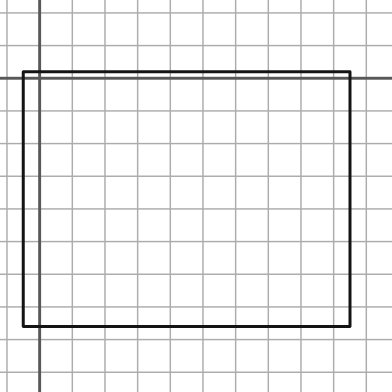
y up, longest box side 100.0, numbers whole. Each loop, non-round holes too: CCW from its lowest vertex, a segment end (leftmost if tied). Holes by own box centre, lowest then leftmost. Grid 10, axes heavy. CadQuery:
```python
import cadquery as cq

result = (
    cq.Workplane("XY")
    .moveTo(-5.0, -76.0)
    .lineTo(95.0, -76.0)
    .lineTo(95.0, 2.0)
    .lineTo(-5.0, 2.0)
    .close()
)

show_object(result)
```